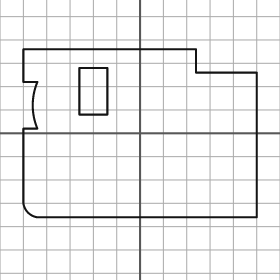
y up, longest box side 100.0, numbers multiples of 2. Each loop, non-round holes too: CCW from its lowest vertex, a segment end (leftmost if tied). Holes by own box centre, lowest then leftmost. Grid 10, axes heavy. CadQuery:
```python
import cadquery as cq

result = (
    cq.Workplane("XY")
    .moveTo(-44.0, -36.0)
    .lineTo(50.0, -36.0)
    .lineTo(50.0, 26.0)
    .lineTo(24.0, 26.0)
    .lineTo(24.0, 36.0)
    .lineTo(-50.0, 36.0)
    .lineTo(-50.0, 22.0)
    .lineTo(-44.0, 22.0)
    .threePointArc((-46.0, 12.0), (-44.0, 2.0))
    .lineTo(-50.0, 2.0)
    .lineTo(-50.0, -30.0)
    .threePointArc((-48.0, -34.0), (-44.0, -36.0))
    .close()
    .moveTo(-26.0, 8.0)
    .lineTo(-14.0, 8.0)
    .lineTo(-14.0, 28.0)
    .lineTo(-26.0, 28.0)
    .close()
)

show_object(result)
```